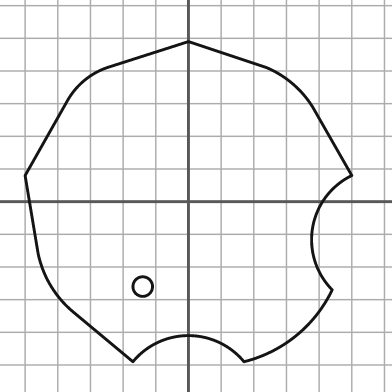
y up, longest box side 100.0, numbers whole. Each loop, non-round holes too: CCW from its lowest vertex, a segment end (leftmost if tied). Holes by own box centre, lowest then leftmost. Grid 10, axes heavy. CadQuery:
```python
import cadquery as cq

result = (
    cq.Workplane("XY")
    .moveTo(-17.0, -49.0)
    .threePointArc((0.0, -41.0), (17.0, -49.0))
    .threePointArc((33.0, -41.0), (44.0, -27.0))
    .threePointArc((38.0, -8.0), (50.0, 8.0))
    .lineTo(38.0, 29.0)
    .threePointArc((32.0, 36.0), (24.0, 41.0))
    .lineTo(0.0, 49.0)
    .lineTo(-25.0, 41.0)
    .threePointArc((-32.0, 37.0), (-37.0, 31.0))
    .lineTo(-50.0, 8.0)
    .lineTo(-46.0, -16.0)
    .threePointArc((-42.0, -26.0), (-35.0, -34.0))
    .close()
    .moveTo(-14.0, -26.0)
    .circle(3.0)
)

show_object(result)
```